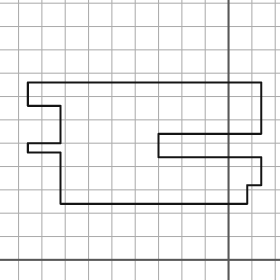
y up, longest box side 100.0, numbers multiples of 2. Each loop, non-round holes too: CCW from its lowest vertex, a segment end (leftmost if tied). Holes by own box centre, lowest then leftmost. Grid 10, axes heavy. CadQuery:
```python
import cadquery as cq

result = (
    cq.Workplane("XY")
    .moveTo(-72.0, 24.0)
    .lineTo(8.0, 24.0)
    .lineTo(8.0, 32.0)
    .lineTo(14.0, 32.0)
    .lineTo(14.0, 44.0)
    .lineTo(-30.0, 44.0)
    .lineTo(-30.0, 54.0)
    .lineTo(14.0, 54.0)
    .lineTo(14.0, 76.0)
    .lineTo(-86.0, 76.0)
    .lineTo(-86.0, 66.0)
    .lineTo(-72.0, 66.0)
    .lineTo(-72.0, 50.0)
    .lineTo(-86.0, 50.0)
    .lineTo(-86.0, 46.0)
    .lineTo(-72.0, 46.0)
    .close()
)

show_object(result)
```